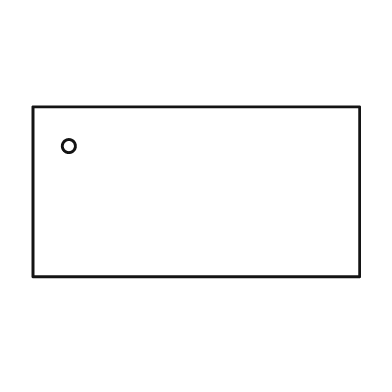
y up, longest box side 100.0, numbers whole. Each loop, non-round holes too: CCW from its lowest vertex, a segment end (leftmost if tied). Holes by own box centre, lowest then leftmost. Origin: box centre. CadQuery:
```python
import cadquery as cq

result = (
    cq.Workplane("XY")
    .moveTo(-50.0, -26.0)
    .lineTo(50.0, -26.0)
    .lineTo(50.0, 26.0)
    .lineTo(-50.0, 26.0)
    .close()
    .moveTo(-39.0, 14.0)
    .circle(2.0)
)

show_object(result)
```